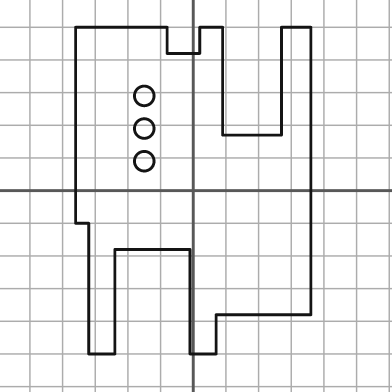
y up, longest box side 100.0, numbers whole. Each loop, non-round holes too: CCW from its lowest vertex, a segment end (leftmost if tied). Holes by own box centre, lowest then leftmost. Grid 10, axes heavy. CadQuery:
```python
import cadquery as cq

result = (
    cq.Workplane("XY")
    .moveTo(-32.0, -50.0)
    .lineTo(-24.0, -50.0)
    .lineTo(-24.0, -18.0)
    .lineTo(-1.0, -18.0)
    .lineTo(-1.0, -50.0)
    .lineTo(7.0, -50.0)
    .lineTo(7.0, -38.0)
    .lineTo(36.0, -38.0)
    .lineTo(36.0, 50.0)
    .lineTo(27.0, 50.0)
    .lineTo(27.0, 17.0)
    .lineTo(9.0, 17.0)
    .lineTo(9.0, 50.0)
    .lineTo(2.0, 50.0)
    .lineTo(2.0, 42.0)
    .lineTo(-8.0, 42.0)
    .lineTo(-8.0, 50.0)
    .lineTo(-36.0, 50.0)
    .lineTo(-36.0, -10.0)
    .lineTo(-32.0, -10.0)
    .close()
    .moveTo(-15.0, 9.0)
    .circle(3.0)
    .moveTo(-15.0, 19.0)
    .circle(3.0)
    .moveTo(-15.0, 29.0)
    .circle(3.0)
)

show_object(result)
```